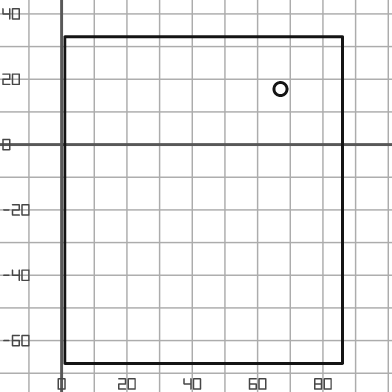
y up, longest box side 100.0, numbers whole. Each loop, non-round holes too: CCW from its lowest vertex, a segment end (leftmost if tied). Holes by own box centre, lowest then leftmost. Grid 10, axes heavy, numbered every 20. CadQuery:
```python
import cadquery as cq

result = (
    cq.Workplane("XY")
    .moveTo(1.0, -67.0)
    .lineTo(86.0, -67.0)
    .lineTo(86.0, 33.0)
    .lineTo(1.0, 33.0)
    .close()
    .moveTo(67.0, 17.0)
    .circle(2.0)
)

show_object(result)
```